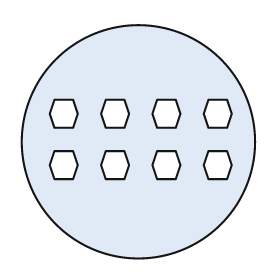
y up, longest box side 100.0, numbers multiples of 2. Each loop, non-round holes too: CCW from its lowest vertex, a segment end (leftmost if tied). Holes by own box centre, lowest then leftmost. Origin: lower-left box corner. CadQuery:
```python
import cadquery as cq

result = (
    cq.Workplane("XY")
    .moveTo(50.0, 50.0)
    .circle(50.0)
    .moveTo(14.0, 34.0)
    .lineTo(22.0, 34.0)
    .lineTo(24.0, 40.0)
    .lineTo(22.0, 46.0)
    .lineTo(14.0, 46.0)
    .lineTo(12.0, 40.0)
    .close()
    .moveTo(36.0, 34.0)
    .lineTo(44.0, 34.0)
    .lineTo(46.0, 40.0)
    .lineTo(44.0, 46.0)
    .lineTo(36.0, 46.0)
    .lineTo(34.0, 40.0)
    .close()
    .moveTo(58.0, 34.0)
    .lineTo(66.0, 34.0)
    .lineTo(68.0, 40.0)
    .lineTo(66.0, 46.0)
    .lineTo(58.0, 46.0)
    .lineTo(56.0, 40.0)
    .close()
    .moveTo(80.0, 34.0)
    .lineTo(88.0, 34.0)
    .lineTo(90.0, 40.0)
    .lineTo(88.0, 46.0)
    .lineTo(80.0, 46.0)
    .lineTo(78.0, 40.0)
    .close()
    .moveTo(14.0, 56.0)
    .lineTo(22.0, 56.0)
    .lineTo(24.0, 62.0)
    .lineTo(22.0, 68.0)
    .lineTo(14.0, 68.0)
    .lineTo(12.0, 62.0)
    .close()
    .moveTo(36.0, 56.0)
    .lineTo(44.0, 56.0)
    .lineTo(46.0, 62.0)
    .lineTo(44.0, 68.0)
    .lineTo(36.0, 68.0)
    .lineTo(34.0, 62.0)
    .close()
    .moveTo(58.0, 56.0)
    .lineTo(66.0, 56.0)
    .lineTo(68.0, 62.0)
    .lineTo(66.0, 68.0)
    .lineTo(58.0, 68.0)
    .lineTo(56.0, 62.0)
    .close()
    .moveTo(80.0, 56.0)
    .lineTo(88.0, 56.0)
    .lineTo(90.0, 62.0)
    .lineTo(88.0, 68.0)
    .lineTo(80.0, 68.0)
    .lineTo(78.0, 62.0)
    .close()
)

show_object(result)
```